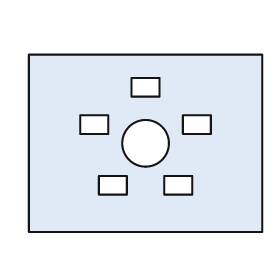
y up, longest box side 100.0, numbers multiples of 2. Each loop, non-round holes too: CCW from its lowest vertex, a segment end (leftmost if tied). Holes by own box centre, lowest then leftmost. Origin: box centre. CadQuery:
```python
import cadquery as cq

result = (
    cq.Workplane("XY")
    .moveTo(-50.0, -38.0)
    .lineTo(50.0, -38.0)
    .lineTo(50.0, 38.0)
    .lineTo(-50.0, 38.0)
    .close()
    .moveTo(-20.0, -22.0)
    .lineTo(-8.0, -22.0)
    .lineTo(-8.0, -14.0)
    .lineTo(-20.0, -14.0)
    .close()
    .moveTo(8.0, -22.0)
    .lineTo(20.0, -22.0)
    .lineTo(20.0, -14.0)
    .lineTo(8.0, -14.0)
    .close()
    .moveTo(0.0, 0.0)
    .circle(10.0)
    .moveTo(-28.0, 4.0)
    .lineTo(-16.0, 4.0)
    .lineTo(-16.0, 12.0)
    .lineTo(-28.0, 12.0)
    .close()
    .moveTo(16.0, 4.0)
    .lineTo(28.0, 4.0)
    .lineTo(28.0, 12.0)
    .lineTo(16.0, 12.0)
    .close()
    .moveTo(-6.0, 20.0)
    .lineTo(6.0, 20.0)
    .lineTo(6.0, 28.0)
    .lineTo(-6.0, 28.0)
    .close()
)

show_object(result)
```